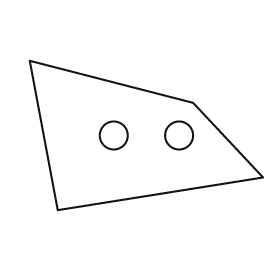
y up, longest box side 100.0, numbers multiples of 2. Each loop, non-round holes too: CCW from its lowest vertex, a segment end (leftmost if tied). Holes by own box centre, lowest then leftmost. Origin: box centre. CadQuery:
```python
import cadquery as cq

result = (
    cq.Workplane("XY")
    .moveTo(-38.0, -32.0)
    .lineTo(50.0, -18.0)
    .lineTo(20.0, 14.0)
    .lineTo(-50.0, 32.0)
    .close()
    .moveTo(-14.0, 0.0)
    .circle(6.0)
    .moveTo(14.0, 0.0)
    .circle(6.0)
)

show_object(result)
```